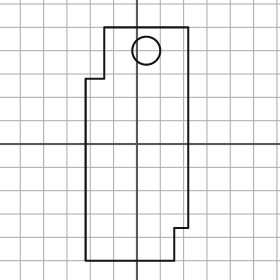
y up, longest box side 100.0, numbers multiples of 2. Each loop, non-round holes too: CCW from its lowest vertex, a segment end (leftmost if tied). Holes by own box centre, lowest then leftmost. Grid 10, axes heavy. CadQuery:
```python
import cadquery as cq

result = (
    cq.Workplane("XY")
    .moveTo(-22.0, -50.0)
    .lineTo(16.0, -50.0)
    .lineTo(16.0, -36.0)
    .lineTo(22.0, -36.0)
    .lineTo(22.0, 50.0)
    .lineTo(-14.0, 50.0)
    .lineTo(-14.0, 28.0)
    .lineTo(-22.0, 28.0)
    .close()
    .moveTo(4.0, 40.0)
    .circle(6.0)
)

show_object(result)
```